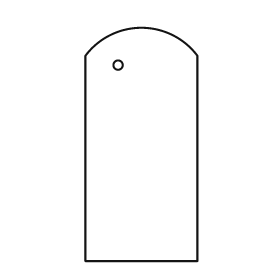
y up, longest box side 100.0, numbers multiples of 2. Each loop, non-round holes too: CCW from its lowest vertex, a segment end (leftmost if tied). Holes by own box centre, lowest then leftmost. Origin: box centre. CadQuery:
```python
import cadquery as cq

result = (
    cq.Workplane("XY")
    .moveTo(-24.0, -50.0)
    .lineTo(24.0, -50.0)
    .lineTo(24.0, 38.0)
    .threePointArc((0.0, 50.0), (-24.0, 38.0))
    .close()
    .moveTo(-10.0, 34.0)
    .circle(2.0)
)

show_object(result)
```